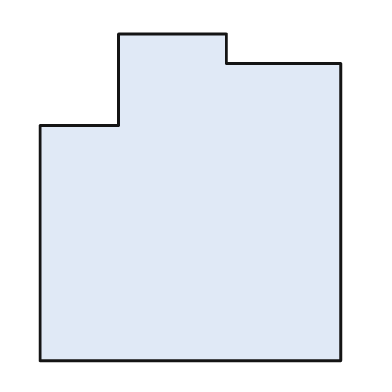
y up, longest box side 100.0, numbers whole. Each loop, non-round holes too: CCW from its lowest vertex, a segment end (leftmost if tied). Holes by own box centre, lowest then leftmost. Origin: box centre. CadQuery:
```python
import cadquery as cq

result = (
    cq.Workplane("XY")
    .moveTo(-46.0, -50.0)
    .lineTo(46.0, -50.0)
    .lineTo(46.0, 41.0)
    .lineTo(11.0, 41.0)
    .lineTo(11.0, 50.0)
    .lineTo(-22.0, 50.0)
    .lineTo(-22.0, 22.0)
    .lineTo(-46.0, 22.0)
    .close()
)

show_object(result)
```